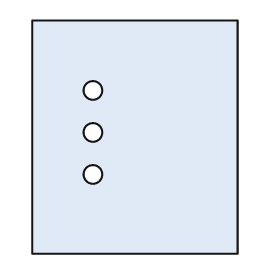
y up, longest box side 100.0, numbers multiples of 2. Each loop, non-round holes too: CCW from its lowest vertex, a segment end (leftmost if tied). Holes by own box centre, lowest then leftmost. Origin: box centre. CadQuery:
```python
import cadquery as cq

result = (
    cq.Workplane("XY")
    .moveTo(-44.0, -50.0)
    .lineTo(44.0, -50.0)
    .lineTo(44.0, 50.0)
    .lineTo(-44.0, 50.0)
    .close()
    .moveTo(-18.0, -16.0)
    .circle(4.0)
    .moveTo(-18.0, 2.0)
    .circle(4.0)
    .moveTo(-18.0, 20.0)
    .circle(4.0)
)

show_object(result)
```